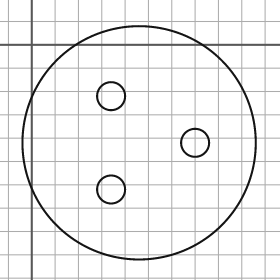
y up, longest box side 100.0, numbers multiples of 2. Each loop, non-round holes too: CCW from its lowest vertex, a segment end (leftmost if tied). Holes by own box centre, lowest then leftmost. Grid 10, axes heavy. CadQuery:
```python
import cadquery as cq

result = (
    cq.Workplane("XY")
    .moveTo(46.0, -42.0)
    .circle(50.0)
    .moveTo(34.0, -62.0)
    .circle(6.0)
    .moveTo(70.0, -42.0)
    .circle(6.0)
    .moveTo(34.0, -22.0)
    .circle(6.0)
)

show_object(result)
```